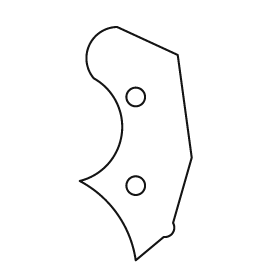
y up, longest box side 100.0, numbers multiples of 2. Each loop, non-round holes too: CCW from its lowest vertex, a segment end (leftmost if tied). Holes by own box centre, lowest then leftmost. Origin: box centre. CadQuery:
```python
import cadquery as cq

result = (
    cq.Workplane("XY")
    .moveTo(0.0, -50.0)
    .lineTo(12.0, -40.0)
    .threePointArc((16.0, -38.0), (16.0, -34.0))
    .lineTo(24.0, -6.0)
    .lineTo(18.0, 38.0)
    .lineTo(-8.0, 50.0)
    .threePointArc((-20.0, 42.0), (-18.0, 28.0))
    .threePointArc((-6.0, 4.0), (-24.0, -16.0))
    .threePointArc((-8.0, -30.0), (0.0, -50.0))
    .close()
    .moveTo(0.0, -18.0)
    .circle(4.0)
    .moveTo(0.0, 20.0)
    .circle(4.0)
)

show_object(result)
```